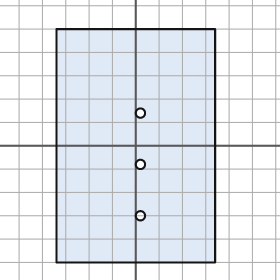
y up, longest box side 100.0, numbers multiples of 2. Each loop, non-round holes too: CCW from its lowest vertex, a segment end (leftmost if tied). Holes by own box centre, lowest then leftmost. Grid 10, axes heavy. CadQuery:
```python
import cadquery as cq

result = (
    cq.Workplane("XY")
    .moveTo(-34.0, -50.0)
    .lineTo(34.0, -50.0)
    .lineTo(34.0, 50.0)
    .lineTo(-34.0, 50.0)
    .close()
    .moveTo(2.0, -30.0)
    .circle(2.0)
    .moveTo(2.0, -8.0)
    .circle(2.0)
    .moveTo(2.0, 14.0)
    .circle(2.0)
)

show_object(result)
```